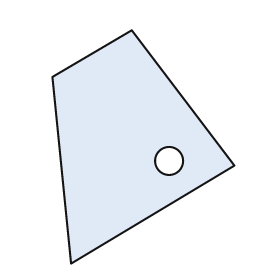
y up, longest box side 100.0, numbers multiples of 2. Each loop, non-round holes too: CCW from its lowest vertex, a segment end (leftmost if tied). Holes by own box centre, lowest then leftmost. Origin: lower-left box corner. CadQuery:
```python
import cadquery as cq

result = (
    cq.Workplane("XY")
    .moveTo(8.0, 0.0)
    .lineTo(78.0, 42.0)
    .lineTo(34.0, 100.0)
    .lineTo(0.0, 80.0)
    .close()
    .moveTo(50.0, 44.0)
    .circle(6.0)
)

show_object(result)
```